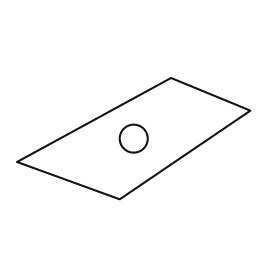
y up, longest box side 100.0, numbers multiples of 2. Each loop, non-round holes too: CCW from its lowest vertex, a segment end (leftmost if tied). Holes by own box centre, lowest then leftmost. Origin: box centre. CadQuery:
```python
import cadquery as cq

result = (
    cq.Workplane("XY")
    .moveTo(-6.0, -26.0)
    .lineTo(50.0, 12.0)
    .lineTo(16.0, 26.0)
    .lineTo(-50.0, -10.0)
    .close()
    .moveTo(0.0, 0.0)
    .circle(6.0)
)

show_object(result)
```